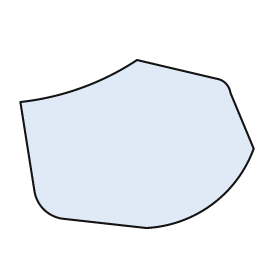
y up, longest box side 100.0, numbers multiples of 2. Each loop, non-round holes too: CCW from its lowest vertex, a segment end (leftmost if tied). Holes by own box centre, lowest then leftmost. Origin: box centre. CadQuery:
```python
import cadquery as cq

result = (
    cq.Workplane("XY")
    .moveTo(4.0, -36.0)
    .threePointArc((32.0, -26.0), (50.0, -2.0))
    .lineTo(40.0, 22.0)
    .threePointArc((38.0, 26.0), (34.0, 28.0))
    .lineTo(0.0, 36.0)
    .threePointArc((-24.0, 24.0), (-50.0, 18.0))
    .lineTo(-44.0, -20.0)
    .threePointArc((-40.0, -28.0), (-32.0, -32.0))
    .close()
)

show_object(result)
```